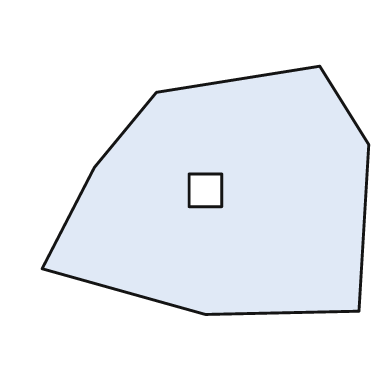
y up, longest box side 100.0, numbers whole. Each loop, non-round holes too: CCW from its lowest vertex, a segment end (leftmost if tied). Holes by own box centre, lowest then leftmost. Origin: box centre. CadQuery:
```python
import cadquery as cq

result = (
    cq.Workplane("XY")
    .moveTo(0.0, -38.0)
    .lineTo(47.0, -37.0)
    .lineTo(50.0, 14.0)
    .lineTo(35.0, 38.0)
    .lineTo(-15.0, 30.0)
    .lineTo(-34.0, 7.0)
    .lineTo(-50.0, -24.0)
    .close()
    .moveTo(-5.0, -5.0)
    .lineTo(5.0, -5.0)
    .lineTo(5.0, 5.0)
    .lineTo(-5.0, 5.0)
    .close()
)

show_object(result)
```